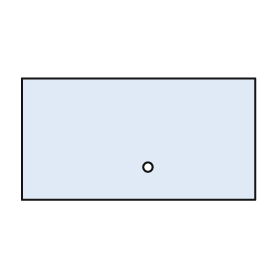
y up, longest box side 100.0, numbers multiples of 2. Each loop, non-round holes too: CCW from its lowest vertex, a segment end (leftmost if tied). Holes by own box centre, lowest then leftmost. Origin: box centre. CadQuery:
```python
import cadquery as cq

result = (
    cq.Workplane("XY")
    .moveTo(-50.0, -26.0)
    .lineTo(50.0, -26.0)
    .lineTo(50.0, 26.0)
    .lineTo(-50.0, 26.0)
    .close()
    .moveTo(4.0, -12.0)
    .circle(2.0)
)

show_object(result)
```